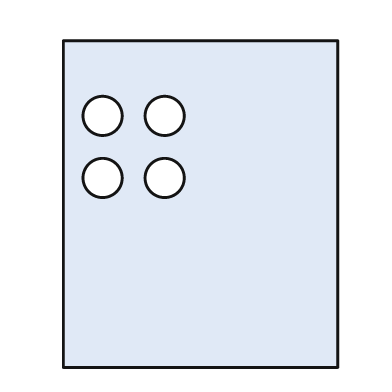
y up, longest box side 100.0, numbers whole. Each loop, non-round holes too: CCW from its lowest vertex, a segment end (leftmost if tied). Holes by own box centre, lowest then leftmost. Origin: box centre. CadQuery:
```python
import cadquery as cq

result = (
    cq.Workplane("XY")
    .moveTo(-42.0, -50.0)
    .lineTo(42.0, -50.0)
    .lineTo(42.0, 50.0)
    .lineTo(-42.0, 50.0)
    .close()
    .moveTo(-30.0, 8.0)
    .circle(6.0)
    .moveTo(-11.0, 8.0)
    .circle(6.0)
    .moveTo(-30.0, 27.0)
    .circle(6.0)
    .moveTo(-11.0, 27.0)
    .circle(6.0)
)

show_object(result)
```